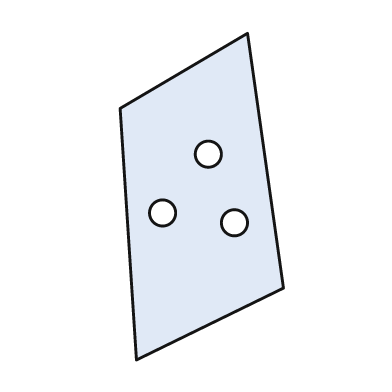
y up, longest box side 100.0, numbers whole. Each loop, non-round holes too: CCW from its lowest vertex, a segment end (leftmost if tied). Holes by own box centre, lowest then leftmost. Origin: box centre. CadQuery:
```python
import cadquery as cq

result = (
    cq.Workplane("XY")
    .moveTo(-20.0, -50.0)
    .lineTo(25.0, -28.0)
    .lineTo(14.0, 50.0)
    .lineTo(-25.0, 27.0)
    .close()
    .moveTo(10.0, -8.0)
    .circle(4.0)
    .moveTo(-12.0, -5.0)
    .circle(4.0)
    .moveTo(2.0, 13.0)
    .circle(4.0)
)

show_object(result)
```